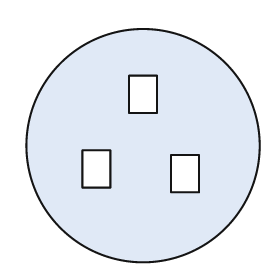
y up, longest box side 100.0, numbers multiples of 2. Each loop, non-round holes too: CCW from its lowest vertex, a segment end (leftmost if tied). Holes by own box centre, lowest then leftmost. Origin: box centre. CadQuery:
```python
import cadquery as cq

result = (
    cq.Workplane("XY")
    .moveTo(0.0, 0.0)
    .circle(50.0)
    .moveTo(12.0, -20.0)
    .lineTo(24.0, -20.0)
    .lineTo(24.0, -4.0)
    .lineTo(12.0, -4.0)
    .close()
    .moveTo(-26.0, -18.0)
    .lineTo(-14.0, -18.0)
    .lineTo(-14.0, -2.0)
    .lineTo(-26.0, -2.0)
    .close()
    .moveTo(-6.0, 14.0)
    .lineTo(6.0, 14.0)
    .lineTo(6.0, 30.0)
    .lineTo(-6.0, 30.0)
    .close()
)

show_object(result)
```